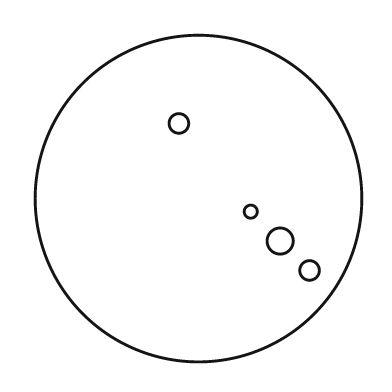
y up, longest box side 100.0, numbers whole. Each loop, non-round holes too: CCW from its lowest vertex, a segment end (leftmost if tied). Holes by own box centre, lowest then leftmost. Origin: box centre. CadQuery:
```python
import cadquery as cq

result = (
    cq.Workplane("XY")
    .moveTo(0.0, 0.0)
    .circle(50.0)
    .moveTo(34.0, -22.0)
    .circle(3.0)
    .moveTo(25.0, -13.0)
    .circle(4.0)
    .moveTo(16.0, -4.0)
    .circle(2.0)
    .moveTo(-6.0, 23.0)
    .circle(3.0)
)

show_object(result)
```